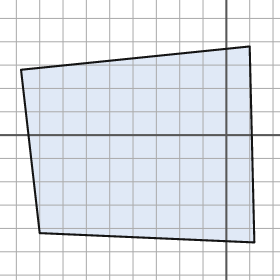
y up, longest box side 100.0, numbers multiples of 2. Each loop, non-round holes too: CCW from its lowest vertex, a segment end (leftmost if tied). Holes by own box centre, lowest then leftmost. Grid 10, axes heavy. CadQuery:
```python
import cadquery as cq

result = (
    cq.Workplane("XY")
    .moveTo(12.0, -46.0)
    .lineTo(10.0, 38.0)
    .lineTo(-88.0, 28.0)
    .lineTo(-80.0, -42.0)
    .close()
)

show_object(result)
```